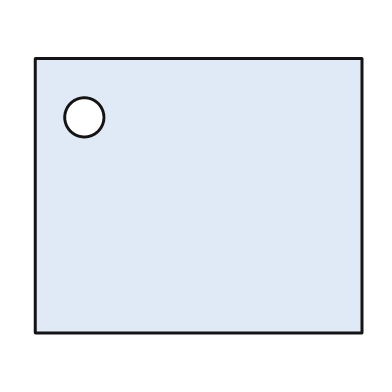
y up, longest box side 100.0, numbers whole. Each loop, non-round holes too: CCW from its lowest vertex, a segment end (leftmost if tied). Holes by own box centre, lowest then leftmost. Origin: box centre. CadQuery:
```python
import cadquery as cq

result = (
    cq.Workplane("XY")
    .moveTo(-50.0, -42.0)
    .lineTo(50.0, -42.0)
    .lineTo(50.0, 42.0)
    .lineTo(-50.0, 42.0)
    .close()
    .moveTo(-35.0, 24.0)
    .circle(6.0)
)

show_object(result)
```